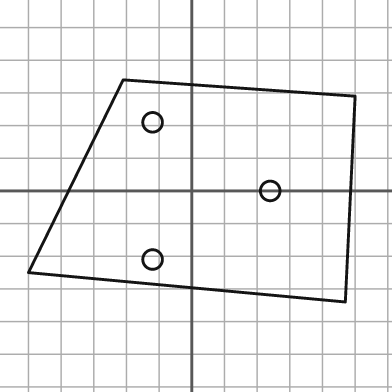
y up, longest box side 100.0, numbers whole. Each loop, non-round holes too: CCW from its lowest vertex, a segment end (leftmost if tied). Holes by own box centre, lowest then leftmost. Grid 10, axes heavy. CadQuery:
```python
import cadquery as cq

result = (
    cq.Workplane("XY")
    .moveTo(47.0, -34.0)
    .lineTo(50.0, 29.0)
    .lineTo(-21.0, 34.0)
    .lineTo(-50.0, -25.0)
    .close()
    .moveTo(-12.0, -21.0)
    .circle(3.0)
    .moveTo(24.0, 0.0)
    .circle(3.0)
    .moveTo(-12.0, 21.0)
    .circle(3.0)
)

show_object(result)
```